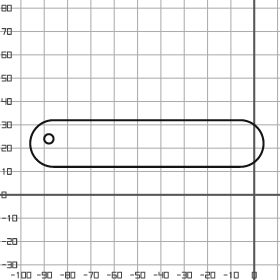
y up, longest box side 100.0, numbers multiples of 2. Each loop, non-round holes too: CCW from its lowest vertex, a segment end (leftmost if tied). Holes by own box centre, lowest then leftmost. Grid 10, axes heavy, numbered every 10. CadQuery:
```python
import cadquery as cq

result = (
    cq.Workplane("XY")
    .moveTo(-86.0, 12.0)
    .lineTo(-6.0, 12.0)
    .threePointArc((4.0, 22.0), (-6.0, 32.0))
    .lineTo(-86.0, 32.0)
    .threePointArc((-96.0, 22.0), (-86.0, 12.0))
    .close()
    .moveTo(-88.0, 24.0)
    .circle(2.0)
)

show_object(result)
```